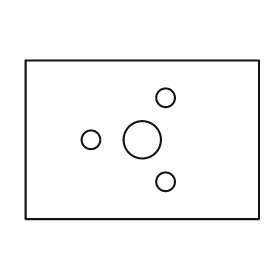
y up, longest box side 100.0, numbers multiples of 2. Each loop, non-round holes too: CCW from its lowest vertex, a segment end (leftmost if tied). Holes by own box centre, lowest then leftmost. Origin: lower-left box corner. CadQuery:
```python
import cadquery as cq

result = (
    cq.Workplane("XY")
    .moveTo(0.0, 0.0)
    .lineTo(100.0, 0.0)
    .lineTo(100.0, 68.0)
    .lineTo(0.0, 68.0)
    .close()
    .moveTo(60.0, 16.0)
    .circle(4.0)
    .moveTo(28.0, 34.0)
    .circle(4.0)
    .moveTo(50.0, 34.0)
    .circle(8.0)
    .moveTo(60.0, 52.0)
    .circle(4.0)
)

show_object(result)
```